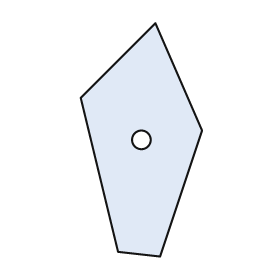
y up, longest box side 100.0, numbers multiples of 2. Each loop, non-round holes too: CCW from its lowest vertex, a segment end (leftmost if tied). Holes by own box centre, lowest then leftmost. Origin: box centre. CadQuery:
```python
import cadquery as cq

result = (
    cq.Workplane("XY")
    .moveTo(8.0, -50.0)
    .lineTo(26.0, 4.0)
    .lineTo(6.0, 50.0)
    .lineTo(-26.0, 18.0)
    .lineTo(-10.0, -48.0)
    .close()
    .moveTo(0.0, 0.0)
    .circle(4.0)
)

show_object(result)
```